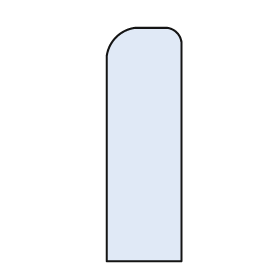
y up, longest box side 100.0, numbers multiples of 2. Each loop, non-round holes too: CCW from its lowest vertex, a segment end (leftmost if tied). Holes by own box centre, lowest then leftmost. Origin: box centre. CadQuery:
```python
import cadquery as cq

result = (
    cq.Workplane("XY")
    .moveTo(-16.0, -50.0)
    .lineTo(16.0, -50.0)
    .lineTo(16.0, 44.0)
    .threePointArc((14.0, 48.0), (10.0, 50.0))
    .lineTo(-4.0, 50.0)
    .threePointArc((-12.0, 46.0), (-16.0, 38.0))
    .close()
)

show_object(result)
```